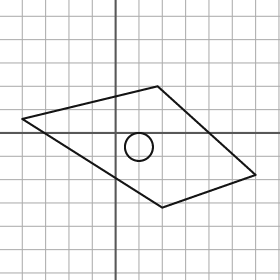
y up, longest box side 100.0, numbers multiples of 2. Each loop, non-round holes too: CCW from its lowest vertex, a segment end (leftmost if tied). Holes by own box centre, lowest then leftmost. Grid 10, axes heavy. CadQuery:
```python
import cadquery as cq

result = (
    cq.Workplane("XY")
    .moveTo(20.0, -32.0)
    .lineTo(60.0, -18.0)
    .lineTo(18.0, 20.0)
    .lineTo(-40.0, 6.0)
    .close()
    .moveTo(10.0, -6.0)
    .circle(6.0)
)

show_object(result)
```